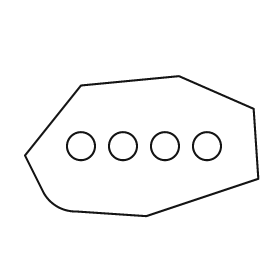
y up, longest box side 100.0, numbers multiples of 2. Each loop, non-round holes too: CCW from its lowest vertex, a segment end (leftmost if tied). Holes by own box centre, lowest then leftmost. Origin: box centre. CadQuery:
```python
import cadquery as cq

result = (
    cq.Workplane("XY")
    .moveTo(2.0, -30.0)
    .lineTo(50.0, -14.0)
    .lineTo(48.0, 16.0)
    .lineTo(16.0, 30.0)
    .lineTo(-26.0, 26.0)
    .lineTo(-50.0, -4.0)
    .lineTo(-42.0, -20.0)
    .threePointArc((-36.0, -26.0), (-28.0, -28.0))
    .close()
    .moveTo(-26.0, 0.0)
    .circle(6.0)
    .moveTo(-8.0, 0.0)
    .circle(6.0)
    .moveTo(10.0, 0.0)
    .circle(6.0)
    .moveTo(28.0, 0.0)
    .circle(6.0)
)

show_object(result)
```